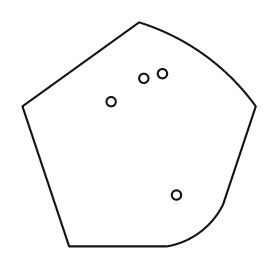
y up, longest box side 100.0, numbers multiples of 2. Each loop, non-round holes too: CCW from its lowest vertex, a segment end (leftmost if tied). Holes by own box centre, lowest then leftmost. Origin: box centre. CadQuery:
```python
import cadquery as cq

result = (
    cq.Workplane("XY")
    .moveTo(-30.0, -48.0)
    .lineTo(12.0, -48.0)
    .threePointArc((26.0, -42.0), (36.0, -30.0))
    .lineTo(50.0, 12.0)
    .threePointArc((28.0, 34.0), (0.0, 48.0))
    .lineTo(-50.0, 12.0)
    .close()
    .moveTo(16.0, -26.0)
    .circle(2.0)
    .moveTo(-12.0, 14.0)
    .circle(2.0)
    .moveTo(2.0, 24.0)
    .circle(2.0)
    .moveTo(10.0, 26.0)
    .circle(2.0)
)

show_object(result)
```